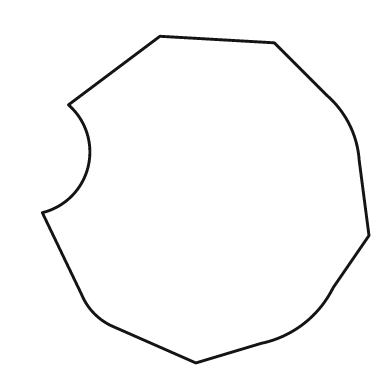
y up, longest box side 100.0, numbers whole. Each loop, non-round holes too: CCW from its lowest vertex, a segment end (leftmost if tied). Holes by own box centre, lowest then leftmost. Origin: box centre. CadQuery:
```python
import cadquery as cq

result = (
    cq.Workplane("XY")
    .moveTo(-3.0, -50.0)
    .lineTo(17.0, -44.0)
    .threePointArc((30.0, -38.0), (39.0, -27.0))
    .lineTo(50.0, -11.0)
    .lineTo(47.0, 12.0)
    .threePointArc((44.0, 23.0), (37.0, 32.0))
    .lineTo(21.0, 48.0)
    .lineTo(-14.0, 50.0)
    .lineTo(-42.0, 29.0)
    .threePointArc((-36.0, 10.0), (-50.0, -4.0))
    .lineTo(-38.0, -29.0)
    .threePointArc((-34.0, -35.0), (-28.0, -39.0))
    .close()
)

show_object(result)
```